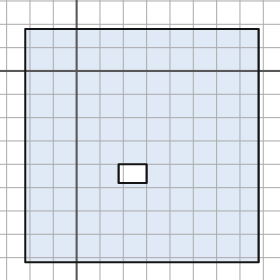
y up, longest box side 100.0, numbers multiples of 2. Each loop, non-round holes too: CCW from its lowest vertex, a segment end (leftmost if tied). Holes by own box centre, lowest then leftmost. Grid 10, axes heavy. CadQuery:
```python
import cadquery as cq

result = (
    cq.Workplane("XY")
    .moveTo(-22.0, -82.0)
    .lineTo(78.0, -82.0)
    .lineTo(78.0, 18.0)
    .lineTo(-22.0, 18.0)
    .close()
    .moveTo(18.0, -48.0)
    .lineTo(30.0, -48.0)
    .lineTo(30.0, -40.0)
    .lineTo(18.0, -40.0)
    .close()
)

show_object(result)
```